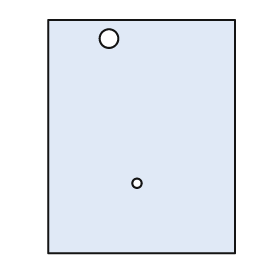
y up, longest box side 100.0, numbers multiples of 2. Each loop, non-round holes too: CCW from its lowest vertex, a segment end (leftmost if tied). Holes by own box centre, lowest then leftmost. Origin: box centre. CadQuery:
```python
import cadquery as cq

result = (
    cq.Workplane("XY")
    .moveTo(-40.0, -50.0)
    .lineTo(40.0, -50.0)
    .lineTo(40.0, 50.0)
    .lineTo(-40.0, 50.0)
    .close()
    .moveTo(-2.0, -20.0)
    .circle(2.0)
    .moveTo(-14.0, 42.0)
    .circle(4.0)
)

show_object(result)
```